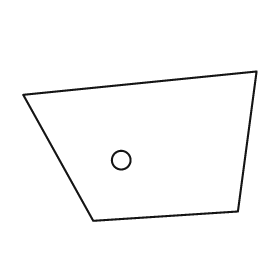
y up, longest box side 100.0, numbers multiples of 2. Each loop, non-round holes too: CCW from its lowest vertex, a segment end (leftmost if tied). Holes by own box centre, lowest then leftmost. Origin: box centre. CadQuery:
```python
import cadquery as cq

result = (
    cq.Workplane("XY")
    .moveTo(-20.0, -32.0)
    .lineTo(42.0, -28.0)
    .lineTo(50.0, 32.0)
    .lineTo(-50.0, 22.0)
    .close()
    .moveTo(-8.0, -6.0)
    .circle(4.0)
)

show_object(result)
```